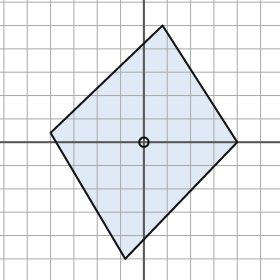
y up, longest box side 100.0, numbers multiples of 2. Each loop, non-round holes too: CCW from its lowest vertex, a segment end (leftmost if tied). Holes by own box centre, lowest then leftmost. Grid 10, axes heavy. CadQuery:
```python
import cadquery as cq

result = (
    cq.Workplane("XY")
    .moveTo(-8.0, -50.0)
    .lineTo(40.0, 0.0)
    .lineTo(8.0, 50.0)
    .lineTo(-40.0, 4.0)
    .close()
    .moveTo(0.0, 0.0)
    .circle(2.0)
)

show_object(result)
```